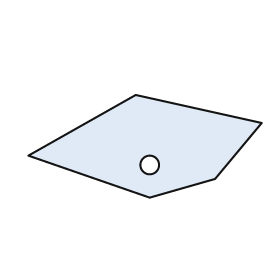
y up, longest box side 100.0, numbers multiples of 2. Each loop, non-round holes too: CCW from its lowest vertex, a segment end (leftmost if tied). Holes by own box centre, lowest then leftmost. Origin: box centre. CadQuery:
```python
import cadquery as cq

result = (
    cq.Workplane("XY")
    .moveTo(2.0, -22.0)
    .lineTo(30.0, -14.0)
    .lineTo(50.0, 10.0)
    .lineTo(-4.0, 22.0)
    .lineTo(-50.0, -4.0)
    .close()
    .moveTo(2.0, -8.0)
    .circle(4.0)
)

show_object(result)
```